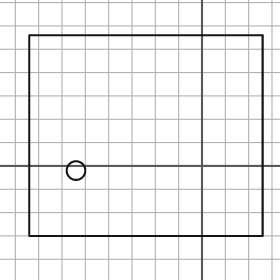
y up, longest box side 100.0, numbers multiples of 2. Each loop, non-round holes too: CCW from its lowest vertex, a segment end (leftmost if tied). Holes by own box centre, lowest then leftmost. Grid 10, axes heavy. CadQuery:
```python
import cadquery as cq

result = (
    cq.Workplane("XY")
    .moveTo(-74.0, -30.0)
    .lineTo(26.0, -30.0)
    .lineTo(26.0, 56.0)
    .lineTo(-74.0, 56.0)
    .close()
    .moveTo(-54.0, -2.0)
    .circle(4.0)
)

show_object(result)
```